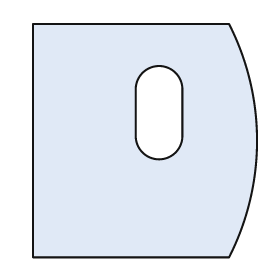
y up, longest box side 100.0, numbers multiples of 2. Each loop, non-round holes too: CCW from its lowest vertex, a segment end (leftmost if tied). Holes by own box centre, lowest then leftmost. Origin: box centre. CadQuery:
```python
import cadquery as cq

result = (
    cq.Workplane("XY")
    .moveTo(-48.0, -50.0)
    .lineTo(36.0, -50.0)
    .threePointArc((48.0, 0.0), (36.0, 50.0))
    .lineTo(-48.0, 50.0)
    .close()
    .moveTo(-4.0, 2.0)
    .threePointArc((6.0, -8.0), (16.0, 2.0))
    .lineTo(16.0, 22.0)
    .threePointArc((6.0, 32.0), (-4.0, 22.0))
    .close()
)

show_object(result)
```